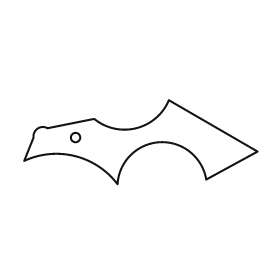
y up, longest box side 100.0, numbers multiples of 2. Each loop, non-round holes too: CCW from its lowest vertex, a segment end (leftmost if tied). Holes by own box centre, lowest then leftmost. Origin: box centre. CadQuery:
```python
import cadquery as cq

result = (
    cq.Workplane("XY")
    .moveTo(-10.0, -18.0)
    .threePointArc((8.0, 0.0), (28.0, -16.0))
    .lineTo(50.0, -4.0)
    .lineTo(12.0, 18.0)
    .threePointArc((-2.0, 6.0), (-20.0, 10.0))
    .lineTo(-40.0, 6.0)
    .threePointArc((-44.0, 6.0), (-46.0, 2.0))
    .lineTo(-50.0, -8.0)
    .threePointArc((-28.0, -6.0), (-10.0, -18.0))
    .close()
    .moveTo(-28.0, 2.0)
    .circle(2.0)
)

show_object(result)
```